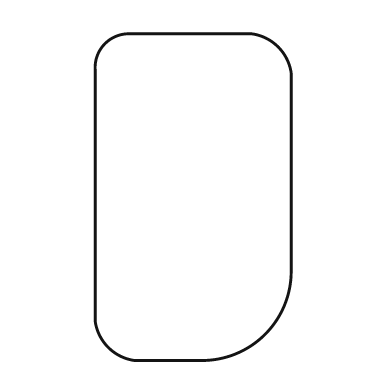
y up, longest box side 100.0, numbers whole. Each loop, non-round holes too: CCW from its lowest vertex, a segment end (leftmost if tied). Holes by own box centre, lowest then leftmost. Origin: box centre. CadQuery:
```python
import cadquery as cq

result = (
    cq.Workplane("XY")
    .moveTo(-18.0, -50.0)
    .lineTo(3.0, -50.0)
    .threePointArc((22.0, -42.0), (30.0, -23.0))
    .lineTo(30.0, 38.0)
    .threePointArc((26.0, 46.0), (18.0, 50.0))
    .lineTo(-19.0, 50.0)
    .threePointArc((-27.0, 47.0), (-30.0, 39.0))
    .lineTo(-30.0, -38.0)
    .threePointArc((-26.0, -46.0), (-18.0, -50.0))
    .close()
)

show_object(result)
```